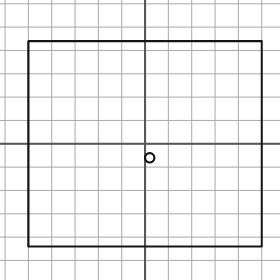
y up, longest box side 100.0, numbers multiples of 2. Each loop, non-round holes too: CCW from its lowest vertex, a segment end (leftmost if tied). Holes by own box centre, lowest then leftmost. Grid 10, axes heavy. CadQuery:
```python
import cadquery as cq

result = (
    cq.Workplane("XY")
    .moveTo(-50.0, -44.0)
    .lineTo(50.0, -44.0)
    .lineTo(50.0, 44.0)
    .lineTo(-50.0, 44.0)
    .close()
    .moveTo(2.0, -6.0)
    .circle(2.0)
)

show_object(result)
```